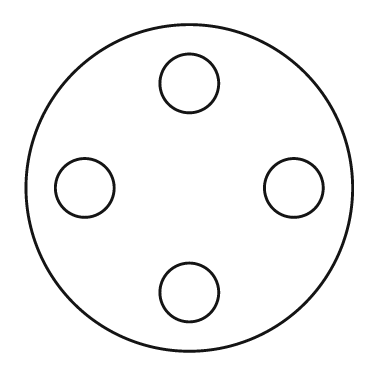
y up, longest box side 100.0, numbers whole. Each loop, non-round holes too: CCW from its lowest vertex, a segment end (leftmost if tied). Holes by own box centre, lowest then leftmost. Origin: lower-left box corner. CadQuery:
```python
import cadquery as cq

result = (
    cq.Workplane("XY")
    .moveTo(50.0, 50.0)
    .circle(50.0)
    .moveTo(50.0, 18.0)
    .circle(9.0)
    .moveTo(18.0, 50.0)
    .circle(9.0)
    .moveTo(82.0, 50.0)
    .circle(9.0)
    .moveTo(50.0, 82.0)
    .circle(9.0)
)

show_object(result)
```